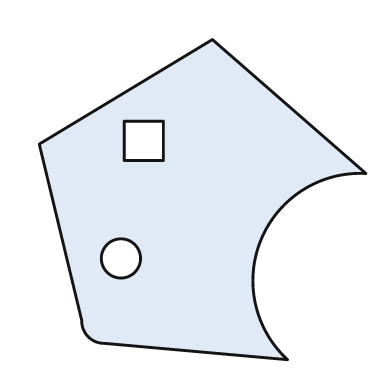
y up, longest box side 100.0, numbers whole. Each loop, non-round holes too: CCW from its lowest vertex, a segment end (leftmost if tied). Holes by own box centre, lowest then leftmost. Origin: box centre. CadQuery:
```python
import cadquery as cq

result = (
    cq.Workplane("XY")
    .moveTo(26.0, -49.0)
    .threePointArc((18.0, -12.0), (50.0, 8.0))
    .lineTo(3.0, 49.0)
    .lineTo(-50.0, 17.0)
    .lineTo(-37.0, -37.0)
    .threePointArc((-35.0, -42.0), (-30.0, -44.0))
    .close()
    .moveTo(-25.0, -18.0)
    .circle(6.0)
    .moveTo(-24.0, 12.0)
    .lineTo(-12.0, 12.0)
    .lineTo(-12.0, 24.0)
    .lineTo(-24.0, 24.0)
    .close()
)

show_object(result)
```